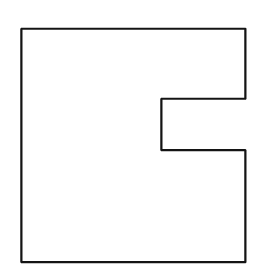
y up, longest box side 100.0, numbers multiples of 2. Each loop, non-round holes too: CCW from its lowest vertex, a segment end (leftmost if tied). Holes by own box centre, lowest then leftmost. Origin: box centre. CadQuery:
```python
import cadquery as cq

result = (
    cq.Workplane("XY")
    .moveTo(-48.0, -50.0)
    .lineTo(48.0, -50.0)
    .lineTo(48.0, -2.0)
    .lineTo(12.0, -2.0)
    .lineTo(12.0, 20.0)
    .lineTo(48.0, 20.0)
    .lineTo(48.0, 50.0)
    .lineTo(-48.0, 50.0)
    .close()
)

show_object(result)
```